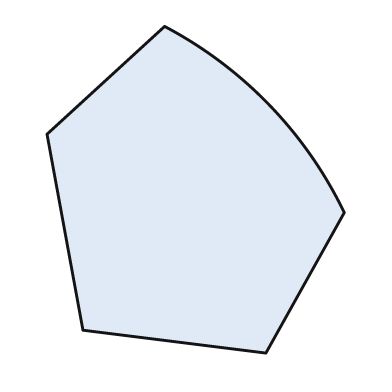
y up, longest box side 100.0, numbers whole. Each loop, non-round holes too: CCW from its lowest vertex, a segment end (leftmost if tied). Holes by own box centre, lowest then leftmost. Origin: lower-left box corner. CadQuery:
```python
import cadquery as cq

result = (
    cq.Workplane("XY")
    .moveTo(67.0, 0.0)
    .lineTo(91.0, 43.0)
    .threePointArc((68.0, 76.0), (36.0, 100.0))
    .lineTo(0.0, 67.0)
    .lineTo(11.0, 7.0)
    .close()
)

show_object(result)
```